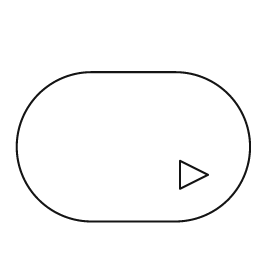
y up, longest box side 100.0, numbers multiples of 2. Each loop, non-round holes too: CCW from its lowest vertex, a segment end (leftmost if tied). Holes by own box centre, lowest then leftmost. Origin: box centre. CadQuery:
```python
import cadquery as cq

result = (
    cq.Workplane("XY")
    .moveTo(-18.0, -32.0)
    .lineTo(18.0, -32.0)
    .threePointArc((50.0, 0.0), (18.0, 32.0))
    .lineTo(-18.0, 32.0)
    .threePointArc((-50.0, 0.0), (-18.0, -32.0))
    .close()
    .moveTo(20.0, -18.0)
    .lineTo(32.0, -12.0)
    .lineTo(20.0, -6.0)
    .close()
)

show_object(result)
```